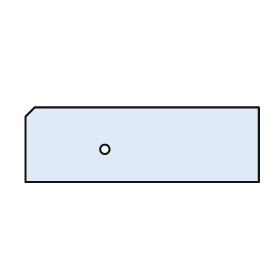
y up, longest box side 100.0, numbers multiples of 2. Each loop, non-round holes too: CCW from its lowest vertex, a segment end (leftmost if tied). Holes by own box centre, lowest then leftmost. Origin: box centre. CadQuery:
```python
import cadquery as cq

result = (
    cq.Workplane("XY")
    .moveTo(-50.0, -16.0)
    .lineTo(50.0, -16.0)
    .lineTo(50.0, 16.0)
    .lineTo(-46.0, 16.0)
    .lineTo(-50.0, 12.0)
    .close()
    .moveTo(-16.0, -2.0)
    .circle(2.0)
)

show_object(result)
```